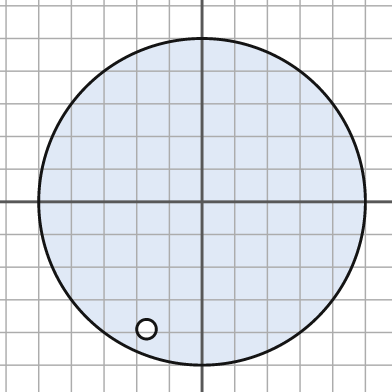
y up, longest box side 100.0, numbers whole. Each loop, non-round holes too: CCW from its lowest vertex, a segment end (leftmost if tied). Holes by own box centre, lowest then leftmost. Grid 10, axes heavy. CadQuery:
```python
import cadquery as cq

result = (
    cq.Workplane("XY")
    .moveTo(0.0, 0.0)
    .circle(50.0)
    .moveTo(-17.0, -39.0)
    .circle(3.0)
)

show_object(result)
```